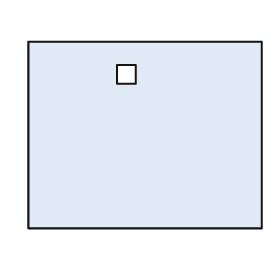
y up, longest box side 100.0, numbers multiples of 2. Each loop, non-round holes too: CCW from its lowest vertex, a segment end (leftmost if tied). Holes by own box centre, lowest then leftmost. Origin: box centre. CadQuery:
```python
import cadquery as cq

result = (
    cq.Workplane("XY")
    .moveTo(-50.0, -40.0)
    .lineTo(50.0, -40.0)
    .lineTo(50.0, 40.0)
    .lineTo(-50.0, 40.0)
    .close()
    .moveTo(-12.0, 22.0)
    .lineTo(-4.0, 22.0)
    .lineTo(-4.0, 30.0)
    .lineTo(-12.0, 30.0)
    .close()
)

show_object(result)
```